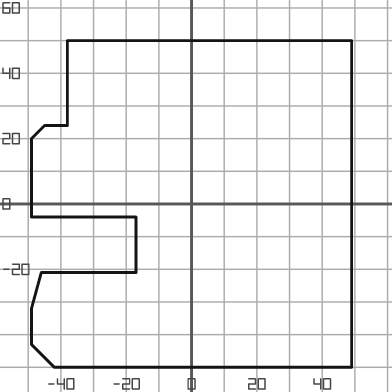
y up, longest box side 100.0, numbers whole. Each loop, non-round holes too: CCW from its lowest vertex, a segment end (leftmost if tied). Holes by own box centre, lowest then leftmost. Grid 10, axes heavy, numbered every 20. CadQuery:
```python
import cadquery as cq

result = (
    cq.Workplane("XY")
    .moveTo(-42.0, -50.0)
    .lineTo(49.0, -50.0)
    .lineTo(49.0, 50.0)
    .lineTo(-38.0, 50.0)
    .lineTo(-38.0, 24.0)
    .lineTo(-45.0, 24.0)
    .lineTo(-49.0, 20.0)
    .lineTo(-49.0, -4.0)
    .lineTo(-17.0, -4.0)
    .lineTo(-17.0, -21.0)
    .lineTo(-46.0, -21.0)
    .lineTo(-49.0, -32.0)
    .lineTo(-49.0, -43.0)
    .close()
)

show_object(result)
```